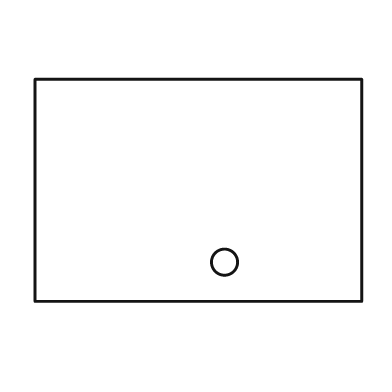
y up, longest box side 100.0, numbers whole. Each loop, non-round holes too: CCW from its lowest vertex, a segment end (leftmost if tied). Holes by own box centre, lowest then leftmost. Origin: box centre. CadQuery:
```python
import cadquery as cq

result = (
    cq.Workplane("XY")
    .moveTo(-50.0, -34.0)
    .lineTo(50.0, -34.0)
    .lineTo(50.0, 34.0)
    .lineTo(-50.0, 34.0)
    .close()
    .moveTo(8.0, -22.0)
    .circle(4.0)
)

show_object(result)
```